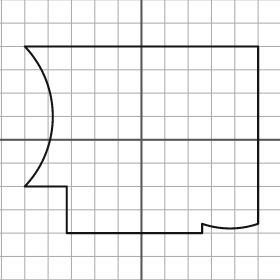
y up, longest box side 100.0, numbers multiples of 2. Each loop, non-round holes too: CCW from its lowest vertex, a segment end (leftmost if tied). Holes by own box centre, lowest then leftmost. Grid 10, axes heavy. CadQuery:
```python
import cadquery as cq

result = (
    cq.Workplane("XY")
    .moveTo(-32.0, -40.0)
    .lineTo(26.0, -40.0)
    .lineTo(26.0, -36.0)
    .threePointArc((38.0, -38.0), (50.0, -36.0))
    .lineTo(50.0, 40.0)
    .lineTo(-50.0, 40.0)
    .threePointArc((-38.0, 10.0), (-50.0, -20.0))
    .lineTo(-32.0, -20.0)
    .close()
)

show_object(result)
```